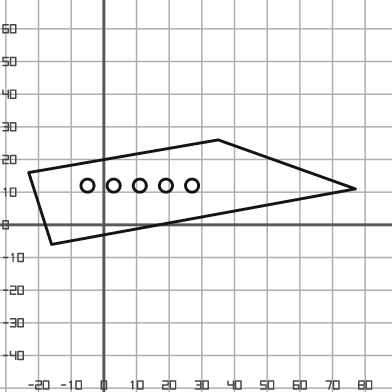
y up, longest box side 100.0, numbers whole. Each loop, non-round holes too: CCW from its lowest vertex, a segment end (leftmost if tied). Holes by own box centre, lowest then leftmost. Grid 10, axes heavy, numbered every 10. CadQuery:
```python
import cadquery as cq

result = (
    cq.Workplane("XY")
    .moveTo(-16.0, -6.0)
    .lineTo(77.0, 11.0)
    .lineTo(35.0, 26.0)
    .lineTo(-23.0, 16.0)
    .close()
    .moveTo(-5.0, 12.0)
    .circle(2.0)
    .moveTo(3.0, 12.0)
    .circle(2.0)
    .moveTo(11.0, 12.0)
    .circle(2.0)
    .moveTo(19.0, 12.0)
    .circle(2.0)
    .moveTo(27.0, 12.0)
    .circle(2.0)
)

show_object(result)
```